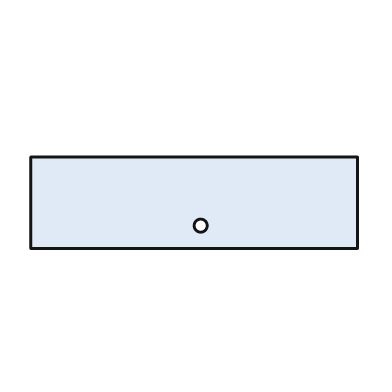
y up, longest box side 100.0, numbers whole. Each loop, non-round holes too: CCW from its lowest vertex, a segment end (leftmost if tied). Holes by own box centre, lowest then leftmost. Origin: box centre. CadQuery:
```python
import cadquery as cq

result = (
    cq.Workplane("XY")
    .moveTo(-50.0, -14.0)
    .lineTo(50.0, -14.0)
    .lineTo(50.0, 14.0)
    .lineTo(-50.0, 14.0)
    .close()
    .moveTo(2.0, -7.0)
    .circle(2.0)
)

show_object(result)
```